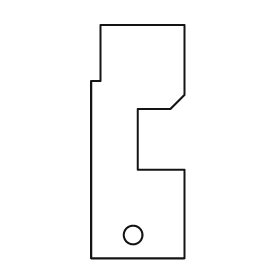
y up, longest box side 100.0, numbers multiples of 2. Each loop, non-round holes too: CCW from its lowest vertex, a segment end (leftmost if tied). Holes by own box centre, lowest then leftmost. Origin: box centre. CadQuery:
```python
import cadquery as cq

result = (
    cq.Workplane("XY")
    .moveTo(-20.0, -50.0)
    .lineTo(20.0, -50.0)
    .lineTo(20.0, -12.0)
    .lineTo(0.0, -12.0)
    .lineTo(0.0, 14.0)
    .lineTo(14.0, 14.0)
    .lineTo(20.0, 20.0)
    .lineTo(20.0, 50.0)
    .lineTo(-16.0, 50.0)
    .lineTo(-16.0, 26.0)
    .lineTo(-20.0, 26.0)
    .close()
    .moveTo(-2.0, -40.0)
    .circle(4.0)
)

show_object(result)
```